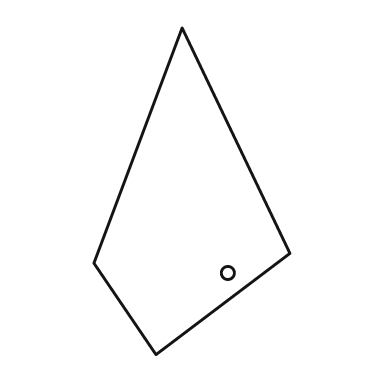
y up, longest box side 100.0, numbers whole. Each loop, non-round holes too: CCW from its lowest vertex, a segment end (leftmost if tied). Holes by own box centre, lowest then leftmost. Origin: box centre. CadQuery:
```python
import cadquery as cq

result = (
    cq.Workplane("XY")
    .moveTo(-11.0, -50.0)
    .lineTo(30.0, -19.0)
    .lineTo(-3.0, 50.0)
    .lineTo(-30.0, -22.0)
    .close()
    .moveTo(11.0, -25.0)
    .circle(2.0)
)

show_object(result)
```